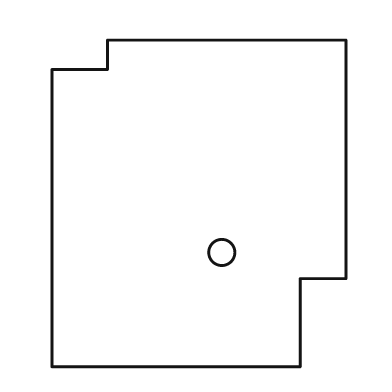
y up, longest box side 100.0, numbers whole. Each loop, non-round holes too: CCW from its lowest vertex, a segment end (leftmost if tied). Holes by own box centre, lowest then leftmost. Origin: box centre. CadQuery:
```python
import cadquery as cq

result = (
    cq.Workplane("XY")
    .moveTo(-45.0, -50.0)
    .lineTo(31.0, -50.0)
    .lineTo(31.0, -23.0)
    .lineTo(45.0, -23.0)
    .lineTo(45.0, 50.0)
    .lineTo(-28.0, 50.0)
    .lineTo(-28.0, 41.0)
    .lineTo(-45.0, 41.0)
    .close()
    .moveTo(7.0, -15.0)
    .circle(4.0)
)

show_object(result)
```